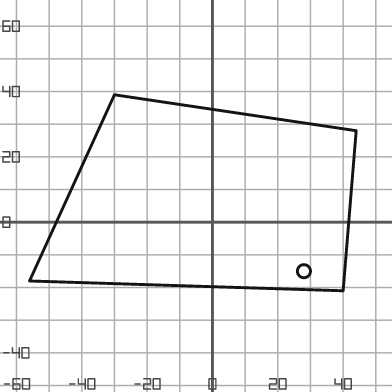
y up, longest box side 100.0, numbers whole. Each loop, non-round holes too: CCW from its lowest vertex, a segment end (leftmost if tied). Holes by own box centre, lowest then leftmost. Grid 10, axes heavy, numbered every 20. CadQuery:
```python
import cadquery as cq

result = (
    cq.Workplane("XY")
    .moveTo(40.0, -21.0)
    .lineTo(44.0, 28.0)
    .lineTo(-30.0, 39.0)
    .lineTo(-56.0, -18.0)
    .close()
    .moveTo(28.0, -15.0)
    .circle(2.0)
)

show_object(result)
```